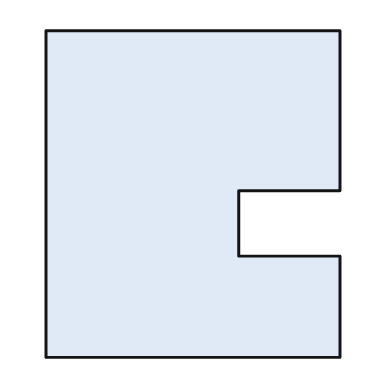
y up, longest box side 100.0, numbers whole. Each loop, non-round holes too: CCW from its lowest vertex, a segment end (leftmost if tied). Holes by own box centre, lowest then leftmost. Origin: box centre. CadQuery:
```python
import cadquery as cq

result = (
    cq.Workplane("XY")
    .moveTo(-45.0, -50.0)
    .lineTo(45.0, -50.0)
    .lineTo(45.0, -19.0)
    .lineTo(14.0, -19.0)
    .lineTo(14.0, 1.0)
    .lineTo(45.0, 1.0)
    .lineTo(45.0, 50.0)
    .lineTo(-45.0, 50.0)
    .close()
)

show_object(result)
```